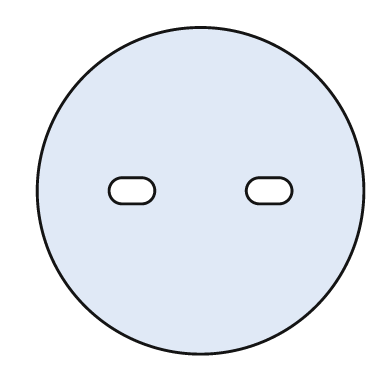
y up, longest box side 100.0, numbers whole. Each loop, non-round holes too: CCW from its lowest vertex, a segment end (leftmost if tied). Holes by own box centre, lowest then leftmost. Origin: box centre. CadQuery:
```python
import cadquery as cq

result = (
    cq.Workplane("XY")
    .moveTo(0.0, 0.0)
    .circle(50.0)
    .moveTo(-24.0, -4.0)
    .lineTo(-18.0, -4.0)
    .threePointArc((-14.0, 0.0), (-18.0, 4.0))
    .lineTo(-24.0, 4.0)
    .threePointArc((-28.0, 0.0), (-24.0, -4.0))
    .close()
    .moveTo(18.0, -4.0)
    .lineTo(24.0, -4.0)
    .threePointArc((28.0, 0.0), (24.0, 4.0))
    .lineTo(18.0, 4.0)
    .threePointArc((14.0, 0.0), (18.0, -4.0))
    .close()
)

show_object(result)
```